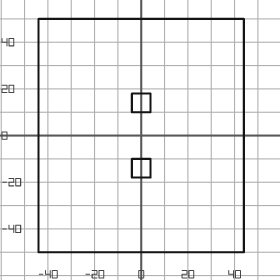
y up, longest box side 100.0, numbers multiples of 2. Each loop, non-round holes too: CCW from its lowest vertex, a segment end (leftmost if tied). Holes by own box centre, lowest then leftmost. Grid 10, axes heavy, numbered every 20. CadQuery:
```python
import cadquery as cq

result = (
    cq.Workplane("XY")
    .moveTo(-44.0, -50.0)
    .lineTo(44.0, -50.0)
    .lineTo(44.0, 50.0)
    .lineTo(-44.0, 50.0)
    .close()
    .moveTo(-4.0, -18.0)
    .lineTo(4.0, -18.0)
    .lineTo(4.0, -10.0)
    .lineTo(-4.0, -10.0)
    .close()
    .moveTo(-4.0, 10.0)
    .lineTo(4.0, 10.0)
    .lineTo(4.0, 18.0)
    .lineTo(-4.0, 18.0)
    .close()
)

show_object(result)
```